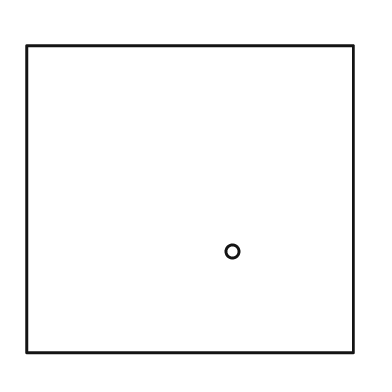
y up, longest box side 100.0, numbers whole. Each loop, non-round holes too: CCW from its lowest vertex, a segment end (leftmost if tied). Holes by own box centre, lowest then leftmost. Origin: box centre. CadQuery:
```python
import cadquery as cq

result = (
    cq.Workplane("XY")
    .moveTo(-50.0, -47.0)
    .lineTo(50.0, -47.0)
    .lineTo(50.0, 47.0)
    .lineTo(-50.0, 47.0)
    .close()
    .moveTo(13.0, -16.0)
    .circle(2.0)
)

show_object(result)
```